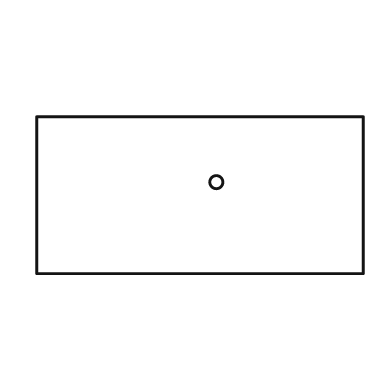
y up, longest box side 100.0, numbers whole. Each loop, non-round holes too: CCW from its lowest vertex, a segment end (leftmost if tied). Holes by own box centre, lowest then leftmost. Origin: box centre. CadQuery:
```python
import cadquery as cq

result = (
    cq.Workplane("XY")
    .moveTo(-50.0, -24.0)
    .lineTo(50.0, -24.0)
    .lineTo(50.0, 24.0)
    .lineTo(-50.0, 24.0)
    .close()
    .moveTo(5.0, 4.0)
    .circle(2.0)
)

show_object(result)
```